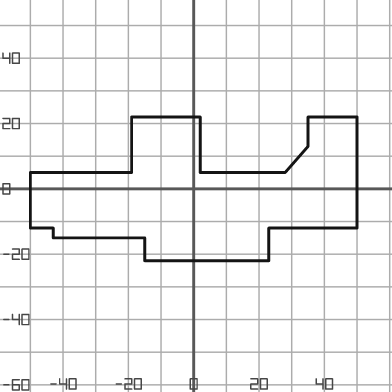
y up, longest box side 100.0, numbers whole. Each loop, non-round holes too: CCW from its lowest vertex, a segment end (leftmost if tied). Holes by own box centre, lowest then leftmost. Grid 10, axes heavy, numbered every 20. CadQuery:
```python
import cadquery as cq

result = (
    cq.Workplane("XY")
    .moveTo(-15.0, -22.0)
    .lineTo(23.0, -22.0)
    .lineTo(23.0, -12.0)
    .lineTo(50.0, -12.0)
    .lineTo(50.0, 22.0)
    .lineTo(35.0, 22.0)
    .lineTo(35.0, 13.0)
    .lineTo(28.0, 5.0)
    .lineTo(2.0, 5.0)
    .lineTo(2.0, 22.0)
    .lineTo(-19.0, 22.0)
    .lineTo(-19.0, 5.0)
    .lineTo(-50.0, 5.0)
    .lineTo(-50.0, -12.0)
    .lineTo(-43.0, -12.0)
    .lineTo(-43.0, -15.0)
    .lineTo(-15.0, -15.0)
    .close()
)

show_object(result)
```